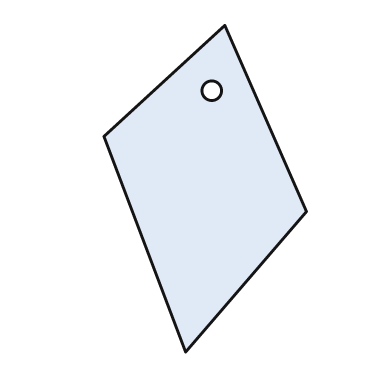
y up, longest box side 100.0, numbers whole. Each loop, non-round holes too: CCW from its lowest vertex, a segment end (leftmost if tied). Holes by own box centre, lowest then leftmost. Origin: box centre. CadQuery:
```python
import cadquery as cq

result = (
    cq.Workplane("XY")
    .moveTo(-6.0, -50.0)
    .lineTo(31.0, -7.0)
    .lineTo(6.0, 50.0)
    .lineTo(-31.0, 16.0)
    .close()
    .moveTo(2.0, 30.0)
    .circle(3.0)
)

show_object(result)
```